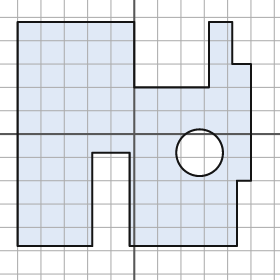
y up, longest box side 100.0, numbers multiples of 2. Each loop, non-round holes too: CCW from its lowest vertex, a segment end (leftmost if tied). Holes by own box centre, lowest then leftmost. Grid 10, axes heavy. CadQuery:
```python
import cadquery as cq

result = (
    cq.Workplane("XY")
    .moveTo(-50.0, -48.0)
    .lineTo(-18.0, -48.0)
    .lineTo(-18.0, -8.0)
    .lineTo(-2.0, -8.0)
    .lineTo(-2.0, -48.0)
    .lineTo(44.0, -48.0)
    .lineTo(44.0, -20.0)
    .lineTo(50.0, -20.0)
    .lineTo(50.0, 30.0)
    .lineTo(42.0, 30.0)
    .lineTo(42.0, 48.0)
    .lineTo(32.0, 48.0)
    .lineTo(32.0, 20.0)
    .lineTo(0.0, 20.0)
    .lineTo(0.0, 48.0)
    .lineTo(-50.0, 48.0)
    .close()
    .moveTo(28.0, -8.0)
    .circle(10.0)
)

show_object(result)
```